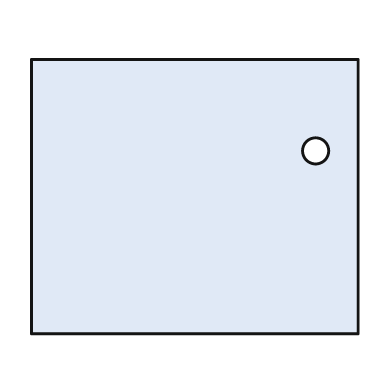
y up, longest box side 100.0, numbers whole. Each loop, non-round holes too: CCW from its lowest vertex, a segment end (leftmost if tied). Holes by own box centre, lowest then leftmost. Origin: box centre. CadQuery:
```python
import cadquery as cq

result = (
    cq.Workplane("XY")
    .moveTo(-50.0, -42.0)
    .lineTo(50.0, -42.0)
    .lineTo(50.0, 42.0)
    .lineTo(-50.0, 42.0)
    .close()
    .moveTo(37.0, 14.0)
    .circle(4.0)
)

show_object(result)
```